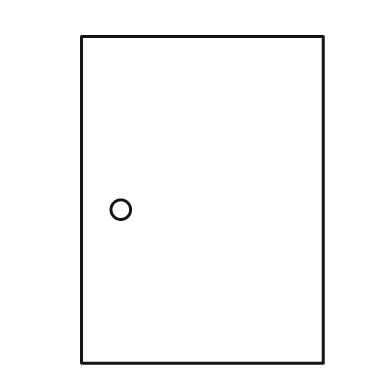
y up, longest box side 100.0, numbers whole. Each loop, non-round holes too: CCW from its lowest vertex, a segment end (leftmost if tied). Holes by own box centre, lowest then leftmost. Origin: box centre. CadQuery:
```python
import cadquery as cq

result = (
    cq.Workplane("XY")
    .moveTo(-37.0, -50.0)
    .lineTo(37.0, -50.0)
    .lineTo(37.0, 50.0)
    .lineTo(-37.0, 50.0)
    .close()
    .moveTo(-25.0, -3.0)
    .circle(3.0)
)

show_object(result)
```